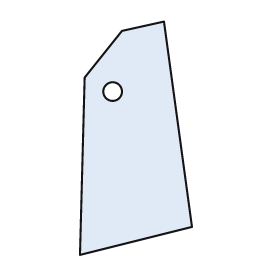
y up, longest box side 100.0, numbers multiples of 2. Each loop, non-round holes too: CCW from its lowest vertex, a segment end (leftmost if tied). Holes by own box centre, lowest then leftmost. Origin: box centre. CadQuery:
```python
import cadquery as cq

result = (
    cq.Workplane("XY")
    .moveTo(-24.0, -50.0)
    .lineTo(24.0, -38.0)
    .lineTo(12.0, 50.0)
    .lineTo(-6.0, 46.0)
    .lineTo(-22.0, 26.0)
    .close()
    .moveTo(-10.0, 20.0)
    .circle(4.0)
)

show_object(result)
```